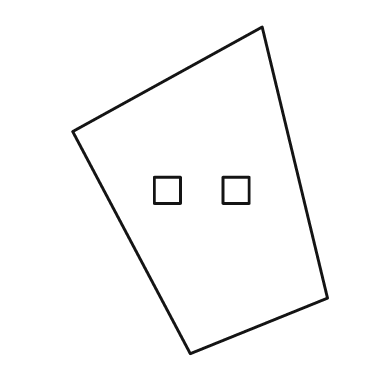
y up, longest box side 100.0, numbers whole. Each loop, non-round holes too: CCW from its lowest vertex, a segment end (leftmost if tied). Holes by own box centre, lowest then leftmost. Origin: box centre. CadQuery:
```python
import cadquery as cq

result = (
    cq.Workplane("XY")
    .moveTo(-3.0, -50.0)
    .lineTo(39.0, -33.0)
    .lineTo(19.0, 50.0)
    .lineTo(-39.0, 18.0)
    .close()
    .moveTo(-14.0, -4.0)
    .lineTo(-6.0, -4.0)
    .lineTo(-6.0, 4.0)
    .lineTo(-14.0, 4.0)
    .close()
    .moveTo(7.0, -4.0)
    .lineTo(15.0, -4.0)
    .lineTo(15.0, 4.0)
    .lineTo(7.0, 4.0)
    .close()
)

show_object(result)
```